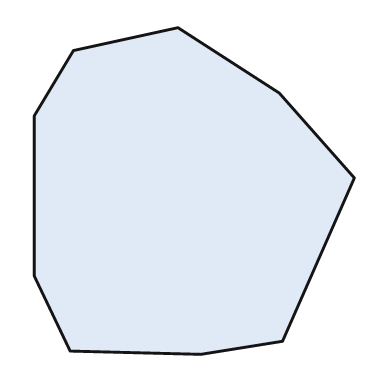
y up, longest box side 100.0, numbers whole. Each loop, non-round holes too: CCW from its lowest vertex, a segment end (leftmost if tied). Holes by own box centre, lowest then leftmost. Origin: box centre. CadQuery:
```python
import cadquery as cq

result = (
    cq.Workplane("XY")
    .moveTo(2.0, -50.0)
    .lineTo(27.0, -46.0)
    .lineTo(49.0, 4.0)
    .lineTo(26.0, 30.0)
    .lineTo(-5.0, 50.0)
    .lineTo(-37.0, 43.0)
    .lineTo(-49.0, 23.0)
    .lineTo(-49.0, -26.0)
    .lineTo(-38.0, -49.0)
    .close()
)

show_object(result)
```